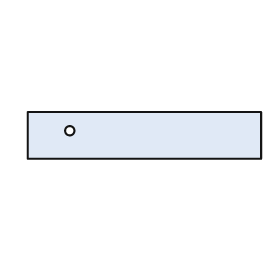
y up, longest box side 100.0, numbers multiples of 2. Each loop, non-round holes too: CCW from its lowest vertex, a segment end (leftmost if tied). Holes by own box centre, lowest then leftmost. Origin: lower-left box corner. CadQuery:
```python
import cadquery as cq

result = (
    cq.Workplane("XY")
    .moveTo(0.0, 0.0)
    .lineTo(100.0, 0.0)
    .lineTo(100.0, 20.0)
    .lineTo(0.0, 20.0)
    .close()
    .moveTo(18.0, 12.0)
    .circle(2.0)
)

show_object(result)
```